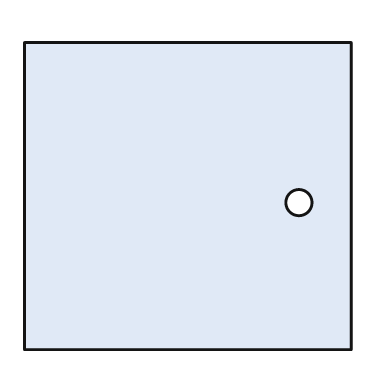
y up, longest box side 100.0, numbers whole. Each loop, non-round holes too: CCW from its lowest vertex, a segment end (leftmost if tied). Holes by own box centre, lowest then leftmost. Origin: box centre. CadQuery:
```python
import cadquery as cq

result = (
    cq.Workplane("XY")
    .moveTo(-50.0, -47.0)
    .lineTo(50.0, -47.0)
    .lineTo(50.0, 47.0)
    .lineTo(-50.0, 47.0)
    .close()
    .moveTo(34.0, -2.0)
    .circle(4.0)
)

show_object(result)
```